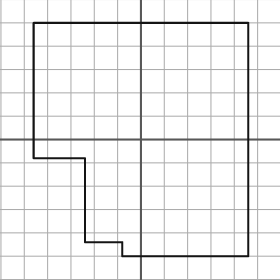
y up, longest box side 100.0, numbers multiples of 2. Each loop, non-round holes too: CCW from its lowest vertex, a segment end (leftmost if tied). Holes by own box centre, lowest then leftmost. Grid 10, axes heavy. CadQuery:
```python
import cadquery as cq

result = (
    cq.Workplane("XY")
    .moveTo(-8.0, -50.0)
    .lineTo(46.0, -50.0)
    .lineTo(46.0, 50.0)
    .lineTo(-46.0, 50.0)
    .lineTo(-46.0, -8.0)
    .lineTo(-24.0, -8.0)
    .lineTo(-24.0, -44.0)
    .lineTo(-8.0, -44.0)
    .close()
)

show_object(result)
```